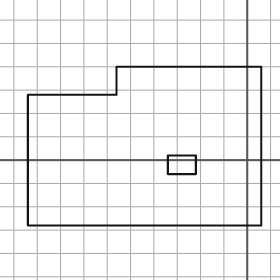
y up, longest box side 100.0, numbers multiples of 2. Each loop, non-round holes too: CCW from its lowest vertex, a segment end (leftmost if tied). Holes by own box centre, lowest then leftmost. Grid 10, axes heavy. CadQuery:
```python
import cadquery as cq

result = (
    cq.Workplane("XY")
    .moveTo(-94.0, -28.0)
    .lineTo(6.0, -28.0)
    .lineTo(6.0, 40.0)
    .lineTo(-56.0, 40.0)
    .lineTo(-56.0, 28.0)
    .lineTo(-94.0, 28.0)
    .close()
    .moveTo(-34.0, -6.0)
    .lineTo(-22.0, -6.0)
    .lineTo(-22.0, 2.0)
    .lineTo(-34.0, 2.0)
    .close()
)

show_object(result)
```